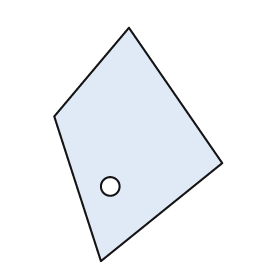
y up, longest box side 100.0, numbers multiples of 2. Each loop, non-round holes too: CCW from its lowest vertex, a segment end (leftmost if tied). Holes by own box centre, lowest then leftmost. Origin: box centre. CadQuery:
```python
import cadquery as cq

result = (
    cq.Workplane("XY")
    .moveTo(-16.0, -50.0)
    .lineTo(36.0, -8.0)
    .lineTo(-4.0, 50.0)
    .lineTo(-36.0, 12.0)
    .close()
    .moveTo(-12.0, -18.0)
    .circle(4.0)
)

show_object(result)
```